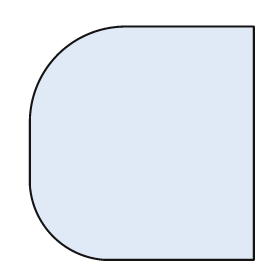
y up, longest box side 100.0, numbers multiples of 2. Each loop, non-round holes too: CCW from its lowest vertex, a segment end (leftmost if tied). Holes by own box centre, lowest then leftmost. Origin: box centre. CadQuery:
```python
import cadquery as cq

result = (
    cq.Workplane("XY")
    .moveTo(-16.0, -50.0)
    .lineTo(48.0, -50.0)
    .lineTo(48.0, 50.0)
    .lineTo(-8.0, 50.0)
    .threePointArc((-36.0, 38.0), (-48.0, 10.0))
    .lineTo(-48.0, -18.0)
    .threePointArc((-38.0, -40.0), (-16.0, -50.0))
    .close()
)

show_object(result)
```